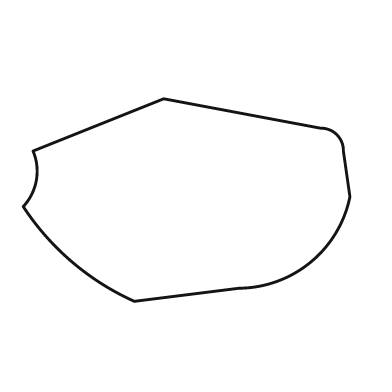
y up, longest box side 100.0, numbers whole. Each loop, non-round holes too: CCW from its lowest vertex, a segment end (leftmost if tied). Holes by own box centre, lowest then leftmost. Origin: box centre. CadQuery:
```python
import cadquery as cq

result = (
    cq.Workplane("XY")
    .moveTo(-16.0, -31.0)
    .lineTo(16.0, -27.0)
    .threePointArc((38.0, -19.0), (50.0, 1.0))
    .lineTo(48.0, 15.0)
    .threePointArc((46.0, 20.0), (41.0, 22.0))
    .lineTo(-7.0, 31.0)
    .lineTo(-47.0, 15.0)
    .threePointArc((-46.0, 6.0), (-50.0, -2.0))
    .threePointArc((-35.0, -19.0), (-16.0, -31.0))
    .close()
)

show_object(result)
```